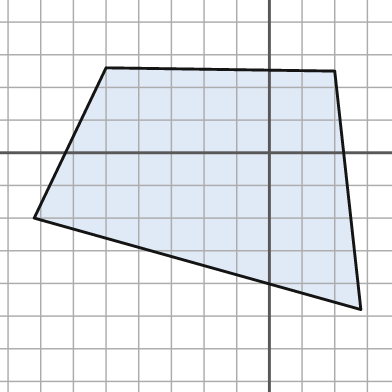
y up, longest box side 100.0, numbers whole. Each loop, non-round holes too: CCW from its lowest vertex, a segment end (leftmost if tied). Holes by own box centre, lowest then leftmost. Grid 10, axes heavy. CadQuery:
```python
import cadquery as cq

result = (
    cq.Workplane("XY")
    .moveTo(28.0, -48.0)
    .lineTo(20.0, 25.0)
    .lineTo(-50.0, 26.0)
    .lineTo(-72.0, -20.0)
    .close()
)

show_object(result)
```